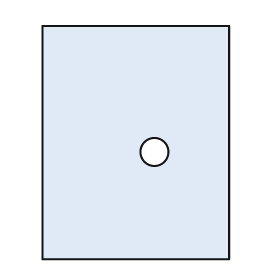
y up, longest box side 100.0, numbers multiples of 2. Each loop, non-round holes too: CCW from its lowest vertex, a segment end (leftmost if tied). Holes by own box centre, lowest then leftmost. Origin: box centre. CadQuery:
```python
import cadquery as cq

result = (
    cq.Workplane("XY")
    .moveTo(-40.0, -50.0)
    .lineTo(40.0, -50.0)
    .lineTo(40.0, 50.0)
    .lineTo(-40.0, 50.0)
    .close()
    .moveTo(8.0, -4.0)
    .circle(6.0)
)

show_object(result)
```